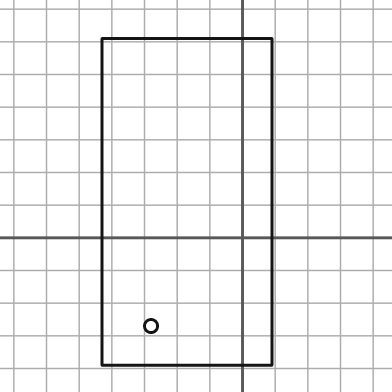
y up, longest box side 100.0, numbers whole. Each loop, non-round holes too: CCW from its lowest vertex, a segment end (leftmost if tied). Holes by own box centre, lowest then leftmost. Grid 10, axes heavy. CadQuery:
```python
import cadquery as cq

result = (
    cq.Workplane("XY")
    .moveTo(-43.0, -39.0)
    .lineTo(9.0, -39.0)
    .lineTo(9.0, 61.0)
    .lineTo(-43.0, 61.0)
    .close()
    .moveTo(-28.0, -27.0)
    .circle(2.0)
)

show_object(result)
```